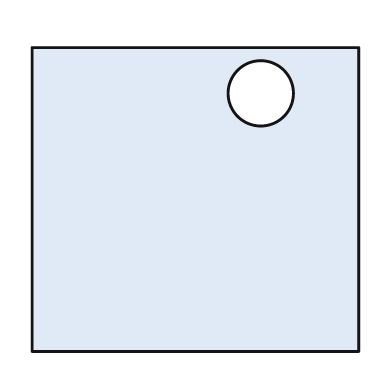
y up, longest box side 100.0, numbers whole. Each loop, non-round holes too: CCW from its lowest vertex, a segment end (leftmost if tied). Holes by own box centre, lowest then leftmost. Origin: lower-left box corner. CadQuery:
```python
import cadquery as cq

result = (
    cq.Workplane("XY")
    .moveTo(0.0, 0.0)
    .lineTo(100.0, 0.0)
    .lineTo(100.0, 93.0)
    .lineTo(0.0, 93.0)
    .close()
    .moveTo(70.0, 79.0)
    .circle(10.0)
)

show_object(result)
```